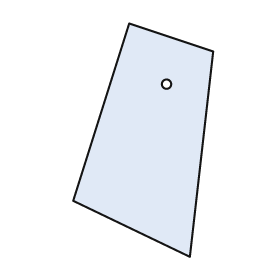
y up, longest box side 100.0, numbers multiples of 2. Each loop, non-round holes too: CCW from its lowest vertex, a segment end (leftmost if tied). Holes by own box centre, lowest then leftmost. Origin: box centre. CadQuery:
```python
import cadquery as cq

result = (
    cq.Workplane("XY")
    .moveTo(20.0, -50.0)
    .lineTo(30.0, 38.0)
    .lineTo(-6.0, 50.0)
    .lineTo(-30.0, -26.0)
    .close()
    .moveTo(10.0, 24.0)
    .circle(2.0)
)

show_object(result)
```